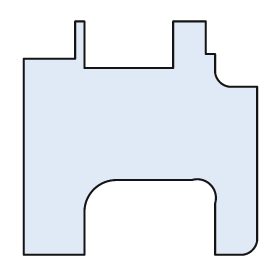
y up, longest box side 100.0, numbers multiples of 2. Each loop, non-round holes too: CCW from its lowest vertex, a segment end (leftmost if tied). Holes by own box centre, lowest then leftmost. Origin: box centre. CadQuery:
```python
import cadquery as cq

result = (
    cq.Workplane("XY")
    .moveTo(-50.0, -50.0)
    .lineTo(-24.0, -50.0)
    .lineTo(-24.0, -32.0)
    .threePointArc((-20.0, -22.0), (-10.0, -18.0))
    .lineTo(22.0, -18.0)
    .threePointArc((30.0, -20.0), (32.0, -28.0))
    .lineTo(32.0, -50.0)
    .lineTo(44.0, -50.0)
    .threePointArc((48.0, -48.0), (50.0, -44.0))
    .lineTo(50.0, 22.0)
    .lineTo(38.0, 22.0)
    .threePointArc((34.0, 24.0), (32.0, 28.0))
    .lineTo(32.0, 36.0)
    .lineTo(28.0, 36.0)
    .lineTo(28.0, 50.0)
    .lineTo(14.0, 50.0)
    .lineTo(14.0, 30.0)
    .lineTo(-24.0, 30.0)
    .lineTo(-24.0, 50.0)
    .lineTo(-28.0, 50.0)
    .lineTo(-28.0, 34.0)
    .lineTo(-50.0, 34.0)
    .close()
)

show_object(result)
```